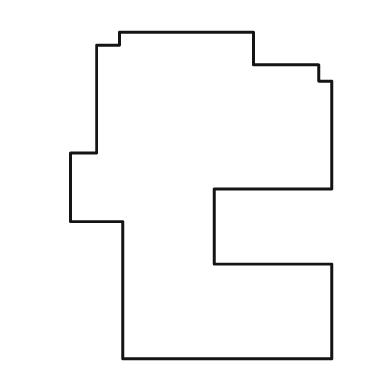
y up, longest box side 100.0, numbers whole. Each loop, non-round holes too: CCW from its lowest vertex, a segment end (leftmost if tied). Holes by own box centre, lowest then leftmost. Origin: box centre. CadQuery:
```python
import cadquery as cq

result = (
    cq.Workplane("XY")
    .moveTo(-24.0, -50.0)
    .lineTo(40.0, -50.0)
    .lineTo(40.0, -21.0)
    .lineTo(4.0, -21.0)
    .lineTo(4.0, 2.0)
    .lineTo(40.0, 2.0)
    .lineTo(40.0, 35.0)
    .lineTo(36.0, 35.0)
    .lineTo(36.0, 40.0)
    .lineTo(16.0, 40.0)
    .lineTo(16.0, 50.0)
    .lineTo(-25.0, 50.0)
    .lineTo(-25.0, 46.0)
    .lineTo(-32.0, 46.0)
    .lineTo(-32.0, 13.0)
    .lineTo(-40.0, 13.0)
    .lineTo(-40.0, -8.0)
    .lineTo(-24.0, -8.0)
    .close()
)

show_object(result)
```